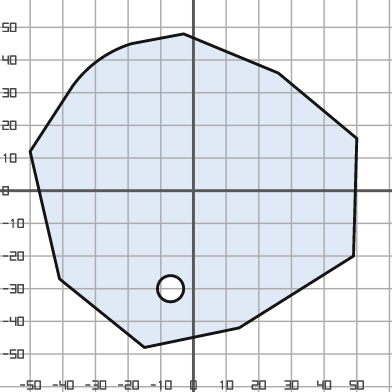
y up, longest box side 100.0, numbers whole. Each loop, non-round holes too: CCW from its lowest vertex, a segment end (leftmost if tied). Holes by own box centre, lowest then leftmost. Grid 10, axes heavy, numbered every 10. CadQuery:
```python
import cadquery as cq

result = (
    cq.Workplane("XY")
    .moveTo(-15.0, -48.0)
    .lineTo(14.0, -42.0)
    .lineTo(49.0, -20.0)
    .lineTo(50.0, 16.0)
    .lineTo(26.0, 36.0)
    .lineTo(-3.0, 48.0)
    .lineTo(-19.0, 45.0)
    .threePointArc((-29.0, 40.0), (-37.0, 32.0))
    .lineTo(-50.0, 12.0)
    .lineTo(-41.0, -27.0)
    .close()
    .moveTo(-7.0, -30.0)
    .circle(4.0)
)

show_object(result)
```